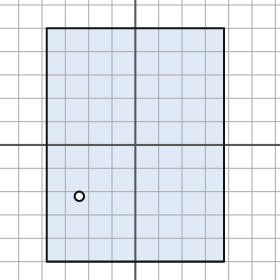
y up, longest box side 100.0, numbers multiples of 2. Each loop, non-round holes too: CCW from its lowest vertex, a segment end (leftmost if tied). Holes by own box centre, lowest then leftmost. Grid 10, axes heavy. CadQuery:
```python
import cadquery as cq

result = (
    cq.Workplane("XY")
    .moveTo(-38.0, -50.0)
    .lineTo(38.0, -50.0)
    .lineTo(38.0, 50.0)
    .lineTo(-38.0, 50.0)
    .close()
    .moveTo(-24.0, -22.0)
    .circle(2.0)
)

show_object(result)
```